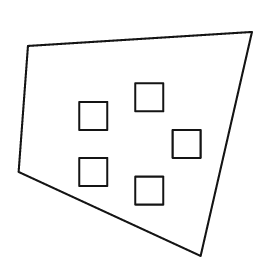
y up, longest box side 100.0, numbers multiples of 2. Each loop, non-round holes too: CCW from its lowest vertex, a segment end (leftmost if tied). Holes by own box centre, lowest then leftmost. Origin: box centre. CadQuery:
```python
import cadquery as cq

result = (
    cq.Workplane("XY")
    .moveTo(28.0, -48.0)
    .lineTo(50.0, 48.0)
    .lineTo(-46.0, 42.0)
    .lineTo(-50.0, -12.0)
    .close()
    .moveTo(0.0, -26.0)
    .lineTo(12.0, -26.0)
    .lineTo(12.0, -14.0)
    .lineTo(0.0, -14.0)
    .close()
    .moveTo(-24.0, -18.0)
    .lineTo(-12.0, -18.0)
    .lineTo(-12.0, -6.0)
    .lineTo(-24.0, -6.0)
    .close()
    .moveTo(16.0, -6.0)
    .lineTo(28.0, -6.0)
    .lineTo(28.0, 6.0)
    .lineTo(16.0, 6.0)
    .close()
    .moveTo(-24.0, 6.0)
    .lineTo(-12.0, 6.0)
    .lineTo(-12.0, 18.0)
    .lineTo(-24.0, 18.0)
    .close()
    .moveTo(0.0, 14.0)
    .lineTo(12.0, 14.0)
    .lineTo(12.0, 26.0)
    .lineTo(0.0, 26.0)
    .close()
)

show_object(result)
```